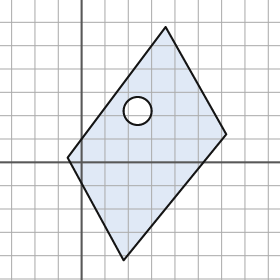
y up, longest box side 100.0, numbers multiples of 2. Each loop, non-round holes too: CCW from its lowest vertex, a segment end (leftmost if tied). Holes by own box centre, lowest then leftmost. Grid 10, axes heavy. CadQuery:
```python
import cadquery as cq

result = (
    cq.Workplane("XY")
    .moveTo(18.0, -42.0)
    .lineTo(62.0, 12.0)
    .lineTo(36.0, 58.0)
    .lineTo(-6.0, 2.0)
    .close()
    .moveTo(24.0, 22.0)
    .circle(6.0)
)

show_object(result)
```